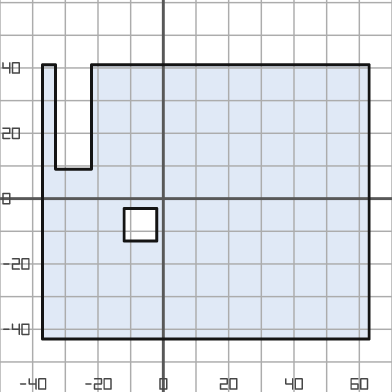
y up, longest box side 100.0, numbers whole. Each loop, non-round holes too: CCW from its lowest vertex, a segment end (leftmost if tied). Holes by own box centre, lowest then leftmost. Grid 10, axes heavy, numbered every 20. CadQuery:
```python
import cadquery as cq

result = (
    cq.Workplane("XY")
    .moveTo(-37.0, -43.0)
    .lineTo(63.0, -43.0)
    .lineTo(63.0, 41.0)
    .lineTo(-22.0, 41.0)
    .lineTo(-22.0, 9.0)
    .lineTo(-33.0, 9.0)
    .lineTo(-33.0, 41.0)
    .lineTo(-37.0, 41.0)
    .close()
    .moveTo(-12.0, -13.0)
    .lineTo(-2.0, -13.0)
    .lineTo(-2.0, -3.0)
    .lineTo(-12.0, -3.0)
    .close()
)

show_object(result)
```